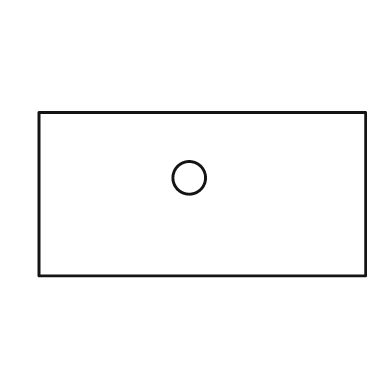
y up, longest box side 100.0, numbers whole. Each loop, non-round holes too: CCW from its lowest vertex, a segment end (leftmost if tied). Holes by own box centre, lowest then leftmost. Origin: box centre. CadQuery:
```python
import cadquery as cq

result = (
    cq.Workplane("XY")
    .moveTo(-50.0, -25.0)
    .lineTo(50.0, -25.0)
    .lineTo(50.0, 25.0)
    .lineTo(-50.0, 25.0)
    .close()
    .moveTo(-4.0, 5.0)
    .circle(5.0)
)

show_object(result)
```